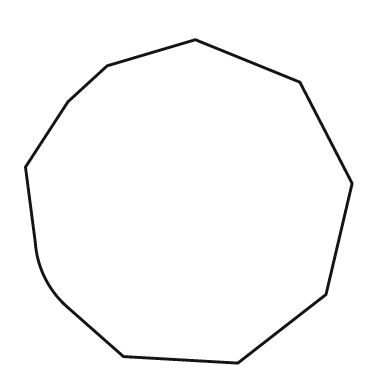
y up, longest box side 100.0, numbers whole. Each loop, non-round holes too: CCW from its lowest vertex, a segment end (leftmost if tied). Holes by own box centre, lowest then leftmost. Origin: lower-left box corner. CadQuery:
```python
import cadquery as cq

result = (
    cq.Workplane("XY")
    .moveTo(65.0, 0.0)
    .lineTo(92.0, 21.0)
    .lineTo(100.0, 55.0)
    .lineTo(84.0, 86.0)
    .lineTo(52.0, 99.0)
    .lineTo(25.0, 91.0)
    .lineTo(13.0, 80.0)
    .lineTo(0.0, 60.0)
    .lineTo(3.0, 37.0)
    .threePointArc((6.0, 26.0), (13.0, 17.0))
    .lineTo(30.0, 2.0)
    .close()
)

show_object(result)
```